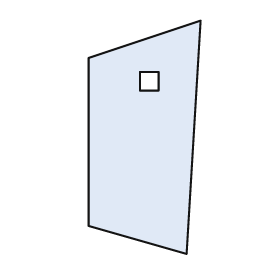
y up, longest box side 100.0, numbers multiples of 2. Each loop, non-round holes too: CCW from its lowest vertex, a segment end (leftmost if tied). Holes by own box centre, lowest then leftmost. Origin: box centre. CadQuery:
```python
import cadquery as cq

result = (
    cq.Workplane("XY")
    .moveTo(18.0, -50.0)
    .lineTo(24.0, 50.0)
    .lineTo(-24.0, 34.0)
    .lineTo(-24.0, -38.0)
    .close()
    .moveTo(-2.0, 20.0)
    .lineTo(6.0, 20.0)
    .lineTo(6.0, 28.0)
    .lineTo(-2.0, 28.0)
    .close()
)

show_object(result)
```